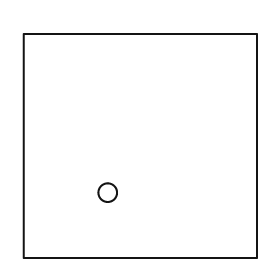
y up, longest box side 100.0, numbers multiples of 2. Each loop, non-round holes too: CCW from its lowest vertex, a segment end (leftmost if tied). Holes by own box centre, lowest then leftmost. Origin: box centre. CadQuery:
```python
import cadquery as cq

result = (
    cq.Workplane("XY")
    .moveTo(-50.0, -48.0)
    .lineTo(50.0, -48.0)
    .lineTo(50.0, 48.0)
    .lineTo(-50.0, 48.0)
    .close()
    .moveTo(-14.0, -20.0)
    .circle(4.0)
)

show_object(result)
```